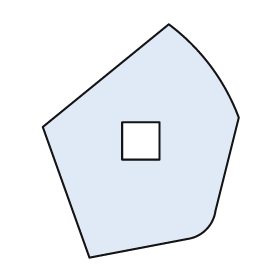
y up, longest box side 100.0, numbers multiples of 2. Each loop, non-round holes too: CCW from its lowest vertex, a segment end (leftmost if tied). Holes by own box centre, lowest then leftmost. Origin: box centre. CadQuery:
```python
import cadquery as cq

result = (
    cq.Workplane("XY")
    .moveTo(-22.0, -50.0)
    .lineTo(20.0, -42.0)
    .threePointArc((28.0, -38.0), (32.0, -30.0))
    .lineTo(42.0, 10.0)
    .threePointArc((30.0, 32.0), (12.0, 50.0))
    .lineTo(-42.0, 6.0)
    .close()
    .moveTo(-8.0, -8.0)
    .lineTo(8.0, -8.0)
    .lineTo(8.0, 8.0)
    .lineTo(-8.0, 8.0)
    .close()
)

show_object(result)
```